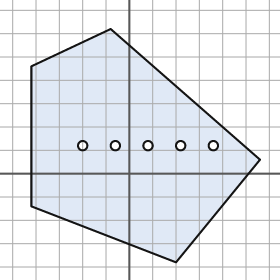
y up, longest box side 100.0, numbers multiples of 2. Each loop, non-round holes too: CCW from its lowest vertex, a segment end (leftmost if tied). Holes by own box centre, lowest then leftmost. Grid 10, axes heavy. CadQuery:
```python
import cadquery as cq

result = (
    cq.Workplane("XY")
    .moveTo(20.0, -38.0)
    .lineTo(56.0, 6.0)
    .lineTo(-8.0, 62.0)
    .lineTo(-42.0, 46.0)
    .lineTo(-42.0, -14.0)
    .close()
    .moveTo(-20.0, 12.0)
    .circle(2.0)
    .moveTo(-6.0, 12.0)
    .circle(2.0)
    .moveTo(8.0, 12.0)
    .circle(2.0)
    .moveTo(22.0, 12.0)
    .circle(2.0)
    .moveTo(36.0, 12.0)
    .circle(2.0)
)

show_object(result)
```